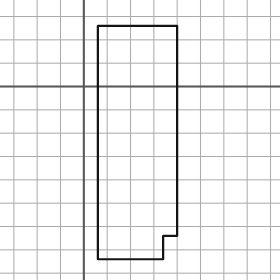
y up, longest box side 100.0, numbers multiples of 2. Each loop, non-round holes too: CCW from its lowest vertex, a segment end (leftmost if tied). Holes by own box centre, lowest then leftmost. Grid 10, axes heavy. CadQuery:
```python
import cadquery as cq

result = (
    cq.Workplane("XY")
    .moveTo(6.0, -74.0)
    .lineTo(34.0, -74.0)
    .lineTo(34.0, -64.0)
    .lineTo(40.0, -64.0)
    .lineTo(40.0, 26.0)
    .lineTo(6.0, 26.0)
    .close()
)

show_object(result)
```